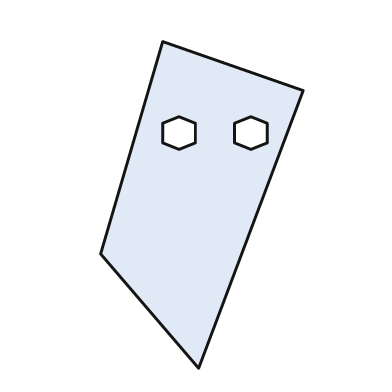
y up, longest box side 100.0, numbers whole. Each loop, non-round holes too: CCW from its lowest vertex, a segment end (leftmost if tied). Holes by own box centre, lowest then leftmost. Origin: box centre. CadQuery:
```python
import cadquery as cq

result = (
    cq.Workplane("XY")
    .moveTo(-1.0, -50.0)
    .lineTo(31.0, 35.0)
    .lineTo(-12.0, 50.0)
    .lineTo(-31.0, -15.0)
    .close()
    .moveTo(-7.0, 17.0)
    .lineTo(-2.0, 19.0)
    .lineTo(-2.0, 25.0)
    .lineTo(-7.0, 27.0)
    .lineTo(-12.0, 25.0)
    .lineTo(-12.0, 19.0)
    .close()
    .moveTo(15.0, 17.0)
    .lineTo(20.0, 19.0)
    .lineTo(20.0, 25.0)
    .lineTo(15.0, 27.0)
    .lineTo(10.0, 25.0)
    .lineTo(10.0, 19.0)
    .close()
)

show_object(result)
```